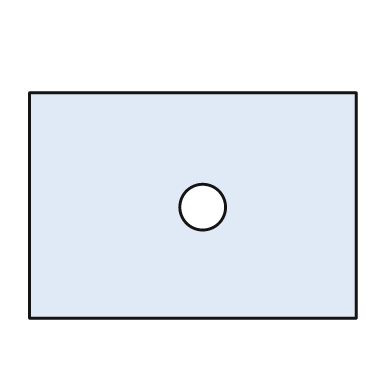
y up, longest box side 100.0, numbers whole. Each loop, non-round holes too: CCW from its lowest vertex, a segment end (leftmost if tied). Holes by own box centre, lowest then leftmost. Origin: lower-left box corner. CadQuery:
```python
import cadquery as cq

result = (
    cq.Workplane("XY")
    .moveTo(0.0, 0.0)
    .lineTo(100.0, 0.0)
    .lineTo(100.0, 69.0)
    .lineTo(0.0, 69.0)
    .close()
    .moveTo(53.0, 34.0)
    .circle(7.0)
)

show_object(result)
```